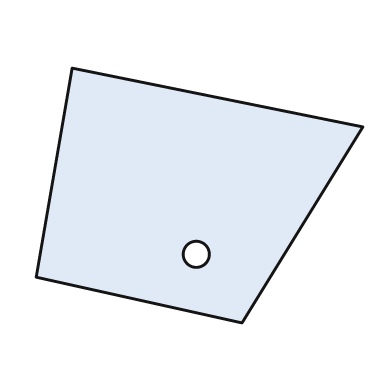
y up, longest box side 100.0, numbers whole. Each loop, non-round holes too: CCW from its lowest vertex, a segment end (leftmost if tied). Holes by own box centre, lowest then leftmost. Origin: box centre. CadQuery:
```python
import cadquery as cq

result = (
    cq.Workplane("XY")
    .moveTo(13.0, -39.0)
    .lineTo(50.0, 21.0)
    .lineTo(-39.0, 39.0)
    .lineTo(-50.0, -25.0)
    .close()
    .moveTo(-1.0, -18.0)
    .circle(4.0)
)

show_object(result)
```